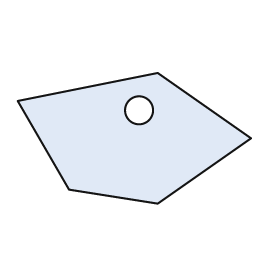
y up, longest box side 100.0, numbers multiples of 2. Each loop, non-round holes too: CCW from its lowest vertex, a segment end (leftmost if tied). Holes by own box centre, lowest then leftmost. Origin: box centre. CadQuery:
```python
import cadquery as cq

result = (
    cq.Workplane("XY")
    .moveTo(10.0, -28.0)
    .lineTo(50.0, 0.0)
    .lineTo(10.0, 28.0)
    .lineTo(-50.0, 16.0)
    .lineTo(-28.0, -22.0)
    .close()
    .moveTo(2.0, 12.0)
    .circle(6.0)
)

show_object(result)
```